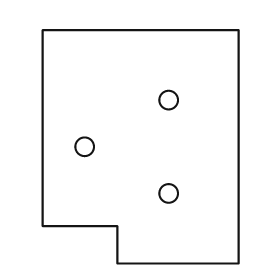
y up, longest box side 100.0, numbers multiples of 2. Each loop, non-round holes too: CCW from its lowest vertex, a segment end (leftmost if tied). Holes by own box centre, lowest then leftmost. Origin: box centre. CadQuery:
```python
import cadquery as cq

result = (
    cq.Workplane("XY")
    .moveTo(-10.0, -50.0)
    .lineTo(42.0, -50.0)
    .lineTo(42.0, 50.0)
    .lineTo(-42.0, 50.0)
    .lineTo(-42.0, -34.0)
    .lineTo(-10.0, -34.0)
    .close()
    .moveTo(12.0, -20.0)
    .circle(4.0)
    .moveTo(-24.0, 0.0)
    .circle(4.0)
    .moveTo(12.0, 20.0)
    .circle(4.0)
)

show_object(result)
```